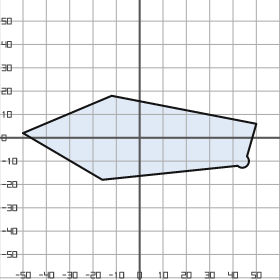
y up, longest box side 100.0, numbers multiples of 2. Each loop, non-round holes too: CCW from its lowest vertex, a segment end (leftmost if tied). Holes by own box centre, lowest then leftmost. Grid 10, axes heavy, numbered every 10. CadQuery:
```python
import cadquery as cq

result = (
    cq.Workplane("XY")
    .moveTo(-16.0, -18.0)
    .lineTo(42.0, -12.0)
    .threePointArc((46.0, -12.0), (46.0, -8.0))
    .lineTo(50.0, 6.0)
    .lineTo(-12.0, 18.0)
    .lineTo(-50.0, 2.0)
    .close()
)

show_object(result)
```